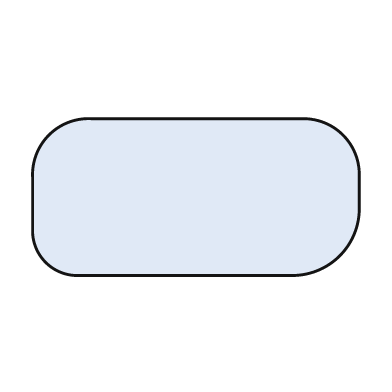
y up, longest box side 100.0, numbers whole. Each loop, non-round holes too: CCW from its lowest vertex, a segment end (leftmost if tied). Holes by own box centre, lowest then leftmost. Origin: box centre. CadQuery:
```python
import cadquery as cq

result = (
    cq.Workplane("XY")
    .moveTo(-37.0, -24.0)
    .lineTo(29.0, -24.0)
    .threePointArc((44.0, -18.0), (50.0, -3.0))
    .lineTo(50.0, 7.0)
    .threePointArc((45.0, 19.0), (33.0, 24.0))
    .lineTo(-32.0, 24.0)
    .threePointArc((-45.0, 19.0), (-50.0, 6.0))
    .lineTo(-50.0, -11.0)
    .threePointArc((-46.0, -20.0), (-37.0, -24.0))
    .close()
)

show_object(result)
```